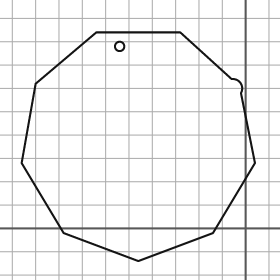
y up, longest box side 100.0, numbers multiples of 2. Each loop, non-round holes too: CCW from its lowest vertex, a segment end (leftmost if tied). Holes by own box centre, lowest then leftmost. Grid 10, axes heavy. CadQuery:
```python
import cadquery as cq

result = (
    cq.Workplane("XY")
    .moveTo(-46.0, -14.0)
    .lineTo(-14.0, -2.0)
    .lineTo(4.0, 28.0)
    .lineTo(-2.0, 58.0)
    .threePointArc((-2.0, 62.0), (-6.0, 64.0))
    .lineTo(-28.0, 84.0)
    .lineTo(-64.0, 84.0)
    .lineTo(-90.0, 62.0)
    .lineTo(-96.0, 28.0)
    .lineTo(-78.0, -2.0)
    .close()
    .moveTo(-54.0, 78.0)
    .circle(2.0)
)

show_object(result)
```